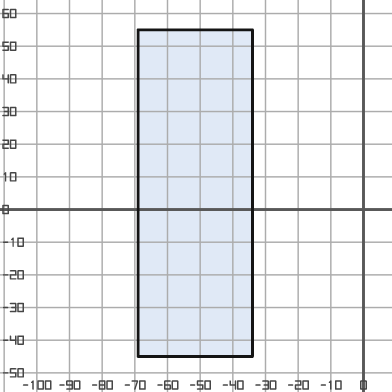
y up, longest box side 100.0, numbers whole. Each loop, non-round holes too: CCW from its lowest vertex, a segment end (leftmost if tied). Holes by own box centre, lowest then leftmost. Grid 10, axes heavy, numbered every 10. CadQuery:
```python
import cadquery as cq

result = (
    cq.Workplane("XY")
    .moveTo(-69.0, -45.0)
    .lineTo(-34.0, -45.0)
    .lineTo(-34.0, 55.0)
    .lineTo(-69.0, 55.0)
    .close()
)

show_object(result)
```